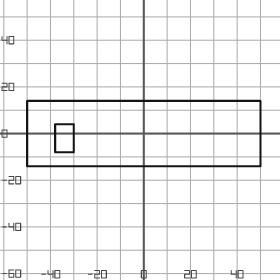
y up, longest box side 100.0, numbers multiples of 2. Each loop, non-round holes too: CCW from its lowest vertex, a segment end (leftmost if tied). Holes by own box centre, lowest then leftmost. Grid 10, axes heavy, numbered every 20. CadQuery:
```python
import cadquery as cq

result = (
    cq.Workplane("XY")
    .moveTo(-50.0, -14.0)
    .lineTo(50.0, -14.0)
    .lineTo(50.0, 14.0)
    .lineTo(-50.0, 14.0)
    .close()
    .moveTo(-38.0, -8.0)
    .lineTo(-30.0, -8.0)
    .lineTo(-30.0, 4.0)
    .lineTo(-38.0, 4.0)
    .close()
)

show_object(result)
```